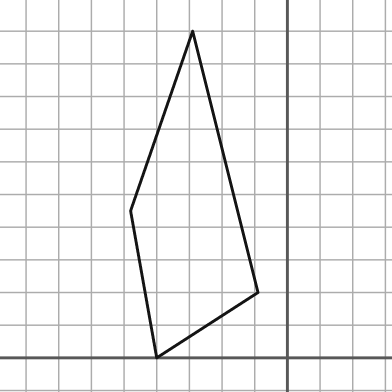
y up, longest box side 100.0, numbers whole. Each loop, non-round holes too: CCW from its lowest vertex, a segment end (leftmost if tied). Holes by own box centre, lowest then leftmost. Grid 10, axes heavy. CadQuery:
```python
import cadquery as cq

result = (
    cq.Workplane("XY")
    .moveTo(-40.0, 0.0)
    .lineTo(-9.0, 20.0)
    .lineTo(-29.0, 100.0)
    .lineTo(-48.0, 45.0)
    .close()
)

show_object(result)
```